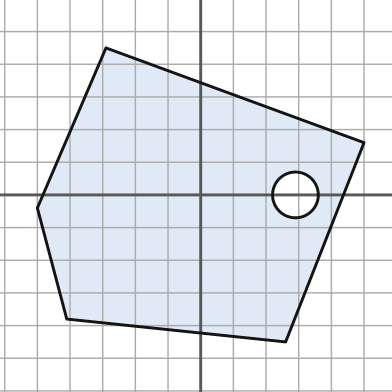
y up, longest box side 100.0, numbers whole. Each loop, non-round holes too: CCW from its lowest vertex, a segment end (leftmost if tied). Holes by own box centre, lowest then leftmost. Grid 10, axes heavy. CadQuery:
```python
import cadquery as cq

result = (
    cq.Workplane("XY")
    .moveTo(26.0, -45.0)
    .lineTo(50.0, 16.0)
    .lineTo(-29.0, 45.0)
    .lineTo(-50.0, -4.0)
    .lineTo(-41.0, -38.0)
    .close()
    .moveTo(29.0, 0.0)
    .circle(7.0)
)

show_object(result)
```